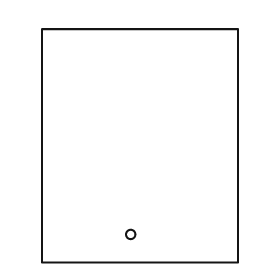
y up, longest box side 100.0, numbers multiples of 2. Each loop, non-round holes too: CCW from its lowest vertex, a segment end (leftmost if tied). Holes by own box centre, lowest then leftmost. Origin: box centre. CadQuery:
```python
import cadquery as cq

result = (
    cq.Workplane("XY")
    .moveTo(-42.0, -50.0)
    .lineTo(42.0, -50.0)
    .lineTo(42.0, 50.0)
    .lineTo(-42.0, 50.0)
    .close()
    .moveTo(-4.0, -38.0)
    .circle(2.0)
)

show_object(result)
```